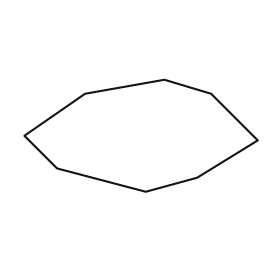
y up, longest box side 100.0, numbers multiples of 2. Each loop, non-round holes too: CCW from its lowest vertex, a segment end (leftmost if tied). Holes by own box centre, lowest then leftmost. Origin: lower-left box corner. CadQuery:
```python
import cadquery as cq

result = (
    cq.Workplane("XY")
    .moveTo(52.0, 0.0)
    .lineTo(74.0, 6.0)
    .lineTo(100.0, 22.0)
    .lineTo(80.0, 42.0)
    .lineTo(60.0, 48.0)
    .lineTo(26.0, 42.0)
    .lineTo(0.0, 24.0)
    .lineTo(14.0, 10.0)
    .close()
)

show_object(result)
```